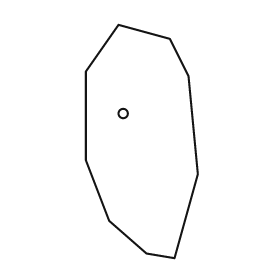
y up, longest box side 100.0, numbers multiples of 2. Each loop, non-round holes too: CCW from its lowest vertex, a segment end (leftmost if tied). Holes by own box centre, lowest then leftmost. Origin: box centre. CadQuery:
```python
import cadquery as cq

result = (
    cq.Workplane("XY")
    .moveTo(14.0, -50.0)
    .lineTo(24.0, -14.0)
    .lineTo(20.0, 28.0)
    .lineTo(12.0, 44.0)
    .lineTo(-10.0, 50.0)
    .lineTo(-24.0, 30.0)
    .lineTo(-24.0, -8.0)
    .lineTo(-14.0, -34.0)
    .lineTo(2.0, -48.0)
    .close()
    .moveTo(-8.0, 12.0)
    .circle(2.0)
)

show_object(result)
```